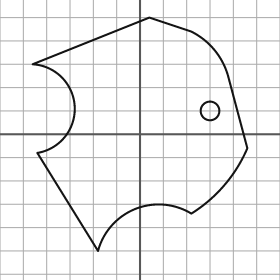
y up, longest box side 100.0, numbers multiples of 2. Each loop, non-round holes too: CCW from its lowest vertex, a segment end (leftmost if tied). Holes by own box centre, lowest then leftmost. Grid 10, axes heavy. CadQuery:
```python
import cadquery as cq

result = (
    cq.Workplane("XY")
    .moveTo(-18.0, -50.0)
    .threePointArc((-2.0, -32.0), (22.0, -34.0))
    .threePointArc((36.0, -22.0), (46.0, -6.0))
    .lineTo(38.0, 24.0)
    .threePointArc((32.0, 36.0), (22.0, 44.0))
    .lineTo(4.0, 50.0)
    .lineTo(-46.0, 30.0)
    .threePointArc((-28.0, 12.0), (-44.0, -8.0))
    .close()
    .moveTo(30.0, 10.0)
    .circle(4.0)
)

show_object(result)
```